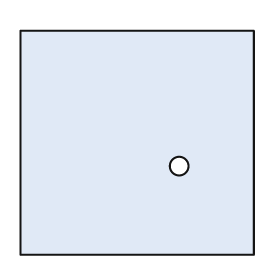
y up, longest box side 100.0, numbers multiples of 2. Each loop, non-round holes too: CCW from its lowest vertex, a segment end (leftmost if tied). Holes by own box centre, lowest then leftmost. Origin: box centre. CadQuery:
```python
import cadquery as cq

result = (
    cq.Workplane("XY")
    .moveTo(-50.0, -48.0)
    .lineTo(50.0, -48.0)
    .lineTo(50.0, 48.0)
    .lineTo(-50.0, 48.0)
    .close()
    .moveTo(18.0, -10.0)
    .circle(4.0)
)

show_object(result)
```